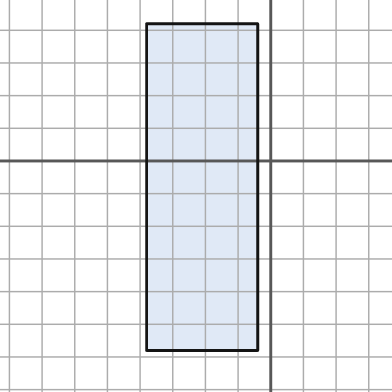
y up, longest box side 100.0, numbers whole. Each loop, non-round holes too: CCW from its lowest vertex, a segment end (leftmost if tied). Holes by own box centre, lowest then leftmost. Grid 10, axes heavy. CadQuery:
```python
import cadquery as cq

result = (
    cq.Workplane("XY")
    .moveTo(-38.0, -58.0)
    .lineTo(-4.0, -58.0)
    .lineTo(-4.0, 42.0)
    .lineTo(-38.0, 42.0)
    .close()
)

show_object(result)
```